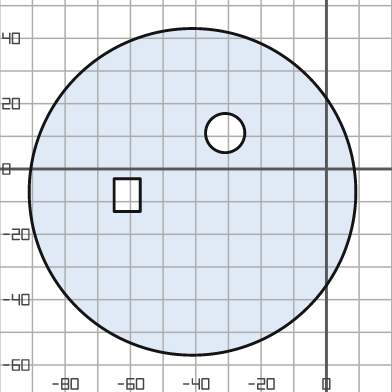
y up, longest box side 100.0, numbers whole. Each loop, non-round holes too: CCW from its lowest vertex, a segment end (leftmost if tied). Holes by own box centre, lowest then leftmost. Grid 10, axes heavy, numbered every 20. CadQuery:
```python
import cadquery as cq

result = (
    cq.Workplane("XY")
    .moveTo(-41.0, -7.0)
    .circle(50.0)
    .moveTo(-65.0, -13.0)
    .lineTo(-57.0, -13.0)
    .lineTo(-57.0, -3.0)
    .lineTo(-65.0, -3.0)
    .close()
    .moveTo(-31.0, 11.0)
    .circle(6.0)
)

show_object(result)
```